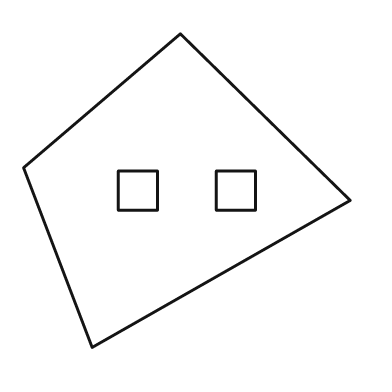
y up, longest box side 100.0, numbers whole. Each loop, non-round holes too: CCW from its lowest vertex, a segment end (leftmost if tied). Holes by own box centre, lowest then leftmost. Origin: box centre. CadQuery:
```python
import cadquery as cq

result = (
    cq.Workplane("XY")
    .moveTo(-29.0, -48.0)
    .lineTo(50.0, -3.0)
    .lineTo(-2.0, 48.0)
    .lineTo(-50.0, 7.0)
    .close()
    .moveTo(-21.0, -6.0)
    .lineTo(-9.0, -6.0)
    .lineTo(-9.0, 6.0)
    .lineTo(-21.0, 6.0)
    .close()
    .moveTo(9.0, -6.0)
    .lineTo(21.0, -6.0)
    .lineTo(21.0, 6.0)
    .lineTo(9.0, 6.0)
    .close()
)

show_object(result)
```